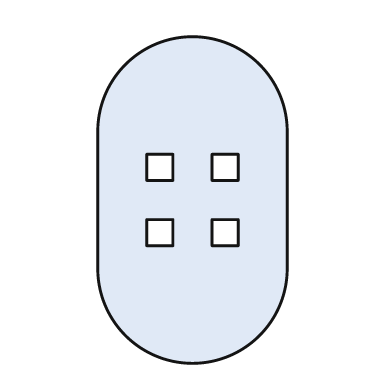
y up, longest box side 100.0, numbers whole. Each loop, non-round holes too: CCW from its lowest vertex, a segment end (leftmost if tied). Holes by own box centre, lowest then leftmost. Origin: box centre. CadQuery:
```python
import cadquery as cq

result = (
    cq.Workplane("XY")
    .moveTo(-29.0, -21.0)
    .threePointArc((0.0, -50.0), (29.0, -21.0))
    .lineTo(29.0, 21.0)
    .threePointArc((0.0, 50.0), (-29.0, 21.0))
    .close()
    .moveTo(-14.0, -14.0)
    .lineTo(-6.0, -14.0)
    .lineTo(-6.0, -6.0)
    .lineTo(-14.0, -6.0)
    .close()
    .moveTo(6.0, -14.0)
    .lineTo(14.0, -14.0)
    .lineTo(14.0, -6.0)
    .lineTo(6.0, -6.0)
    .close()
    .moveTo(-14.0, 6.0)
    .lineTo(-6.0, 6.0)
    .lineTo(-6.0, 14.0)
    .lineTo(-14.0, 14.0)
    .close()
    .moveTo(6.0, 6.0)
    .lineTo(14.0, 6.0)
    .lineTo(14.0, 14.0)
    .lineTo(6.0, 14.0)
    .close()
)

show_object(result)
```